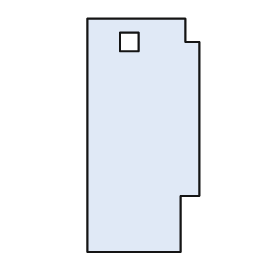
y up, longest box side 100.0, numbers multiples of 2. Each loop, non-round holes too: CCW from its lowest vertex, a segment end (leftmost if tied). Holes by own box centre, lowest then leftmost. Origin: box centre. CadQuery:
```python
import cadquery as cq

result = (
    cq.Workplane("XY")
    .moveTo(-24.0, -50.0)
    .lineTo(16.0, -50.0)
    .lineTo(16.0, -26.0)
    .lineTo(24.0, -26.0)
    .lineTo(24.0, 40.0)
    .lineTo(18.0, 40.0)
    .lineTo(18.0, 50.0)
    .lineTo(-24.0, 50.0)
    .close()
    .moveTo(-10.0, 36.0)
    .lineTo(-2.0, 36.0)
    .lineTo(-2.0, 44.0)
    .lineTo(-10.0, 44.0)
    .close()
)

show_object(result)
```